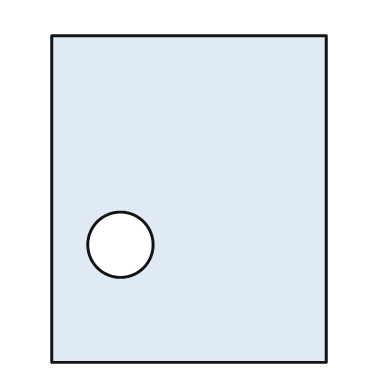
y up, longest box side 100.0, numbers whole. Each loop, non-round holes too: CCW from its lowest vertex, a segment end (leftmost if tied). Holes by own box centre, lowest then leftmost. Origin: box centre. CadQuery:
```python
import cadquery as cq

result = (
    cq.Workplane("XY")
    .moveTo(-42.0, -50.0)
    .lineTo(42.0, -50.0)
    .lineTo(42.0, 50.0)
    .lineTo(-42.0, 50.0)
    .close()
    .moveTo(-21.0, -14.0)
    .circle(10.0)
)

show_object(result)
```